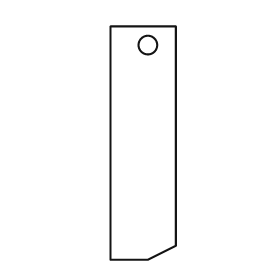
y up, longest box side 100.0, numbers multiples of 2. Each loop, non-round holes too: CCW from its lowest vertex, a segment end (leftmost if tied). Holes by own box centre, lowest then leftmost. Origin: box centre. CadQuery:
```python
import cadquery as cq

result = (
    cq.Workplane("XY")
    .moveTo(-14.0, -50.0)
    .lineTo(2.0, -50.0)
    .lineTo(14.0, -44.0)
    .lineTo(14.0, 50.0)
    .lineTo(-14.0, 50.0)
    .close()
    .moveTo(2.0, 42.0)
    .circle(4.0)
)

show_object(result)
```